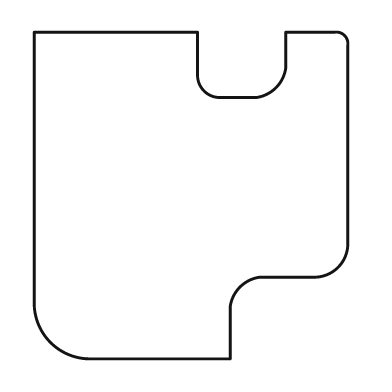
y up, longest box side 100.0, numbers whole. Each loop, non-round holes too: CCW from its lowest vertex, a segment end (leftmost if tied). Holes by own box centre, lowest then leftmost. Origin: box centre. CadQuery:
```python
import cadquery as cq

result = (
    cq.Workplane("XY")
    .moveTo(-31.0, -50.0)
    .lineTo(12.0, -50.0)
    .lineTo(12.0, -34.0)
    .threePointArc((15.0, -28.0), (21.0, -25.0))
    .lineTo(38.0, -25.0)
    .threePointArc((45.0, -22.0), (48.0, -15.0))
    .lineTo(48.0, 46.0)
    .threePointArc((47.0, 49.0), (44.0, 50.0))
    .lineTo(29.0, 50.0)
    .lineTo(29.0, 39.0)
    .threePointArc((26.0, 33.0), (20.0, 30.0))
    .lineTo(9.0, 30.0)
    .threePointArc((4.0, 32.0), (2.0, 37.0))
    .lineTo(2.0, 50.0)
    .lineTo(-48.0, 50.0)
    .lineTo(-48.0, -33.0)
    .threePointArc((-43.0, -45.0), (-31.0, -50.0))
    .close()
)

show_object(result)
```